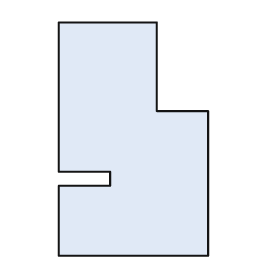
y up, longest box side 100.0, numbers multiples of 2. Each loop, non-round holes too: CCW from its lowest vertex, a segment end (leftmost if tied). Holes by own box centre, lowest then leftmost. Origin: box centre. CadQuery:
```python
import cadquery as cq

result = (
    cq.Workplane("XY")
    .moveTo(-32.0, -50.0)
    .lineTo(32.0, -50.0)
    .lineTo(32.0, 12.0)
    .lineTo(10.0, 12.0)
    .lineTo(10.0, 50.0)
    .lineTo(-32.0, 50.0)
    .lineTo(-32.0, -14.0)
    .lineTo(-10.0, -14.0)
    .lineTo(-10.0, -20.0)
    .lineTo(-32.0, -20.0)
    .close()
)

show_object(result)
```